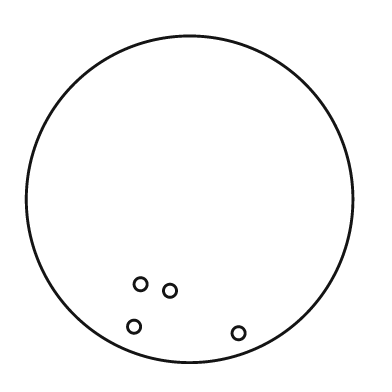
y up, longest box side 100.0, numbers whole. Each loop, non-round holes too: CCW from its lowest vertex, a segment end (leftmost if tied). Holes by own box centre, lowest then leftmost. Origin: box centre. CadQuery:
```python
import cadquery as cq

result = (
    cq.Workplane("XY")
    .moveTo(0.0, 0.0)
    .circle(50.0)
    .moveTo(15.0, -41.0)
    .circle(2.0)
    .moveTo(-17.0, -39.0)
    .circle(2.0)
    .moveTo(-6.0, -28.0)
    .circle(2.0)
    .moveTo(-15.0, -26.0)
    .circle(2.0)
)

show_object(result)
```